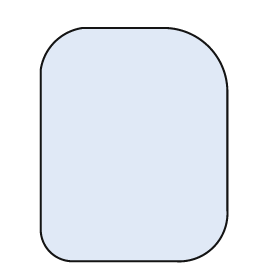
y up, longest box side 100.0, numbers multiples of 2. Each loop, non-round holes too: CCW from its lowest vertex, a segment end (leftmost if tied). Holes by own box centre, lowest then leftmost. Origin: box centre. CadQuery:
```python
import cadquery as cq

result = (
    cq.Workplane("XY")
    .moveTo(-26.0, -50.0)
    .lineTo(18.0, -50.0)
    .threePointArc((34.0, -44.0), (40.0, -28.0))
    .lineTo(40.0, 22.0)
    .threePointArc((32.0, 42.0), (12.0, 50.0))
    .lineTo(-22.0, 50.0)
    .threePointArc((-34.0, 44.0), (-40.0, 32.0))
    .lineTo(-40.0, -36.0)
    .threePointArc((-36.0, -46.0), (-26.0, -50.0))
    .close()
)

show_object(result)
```